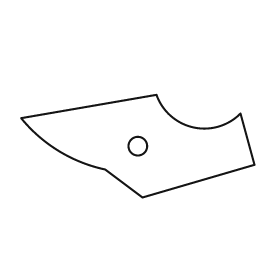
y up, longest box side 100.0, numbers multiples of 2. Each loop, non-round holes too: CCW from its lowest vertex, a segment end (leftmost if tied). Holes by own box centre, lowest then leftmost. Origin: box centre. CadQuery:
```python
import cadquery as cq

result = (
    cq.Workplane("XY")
    .moveTo(2.0, -22.0)
    .lineTo(50.0, -8.0)
    .lineTo(44.0, 14.0)
    .threePointArc((24.0, 8.0), (8.0, 22.0))
    .lineTo(-50.0, 12.0)
    .threePointArc((-34.0, -2.0), (-14.0, -10.0))
    .close()
    .moveTo(0.0, 0.0)
    .circle(4.0)
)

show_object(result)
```